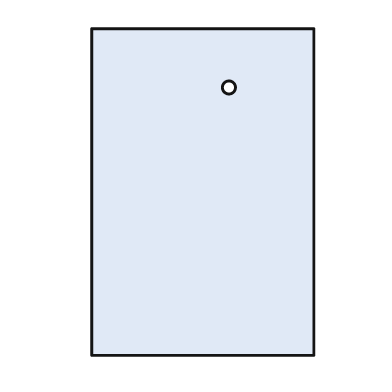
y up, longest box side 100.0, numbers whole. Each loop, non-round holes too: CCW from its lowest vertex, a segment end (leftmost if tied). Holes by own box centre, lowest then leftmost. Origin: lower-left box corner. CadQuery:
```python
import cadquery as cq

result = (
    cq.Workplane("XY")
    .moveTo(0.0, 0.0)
    .lineTo(68.0, 0.0)
    .lineTo(68.0, 100.0)
    .lineTo(0.0, 100.0)
    .close()
    .moveTo(42.0, 82.0)
    .circle(2.0)
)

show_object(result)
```